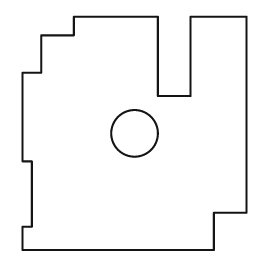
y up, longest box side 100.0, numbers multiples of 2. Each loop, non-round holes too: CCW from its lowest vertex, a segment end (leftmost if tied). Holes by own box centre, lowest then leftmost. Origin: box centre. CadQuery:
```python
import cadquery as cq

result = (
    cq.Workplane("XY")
    .moveTo(-48.0, -50.0)
    .lineTo(34.0, -50.0)
    .lineTo(34.0, -34.0)
    .lineTo(48.0, -34.0)
    .lineTo(48.0, 50.0)
    .lineTo(24.0, 50.0)
    .lineTo(24.0, 16.0)
    .lineTo(10.0, 16.0)
    .lineTo(10.0, 50.0)
    .lineTo(-26.0, 50.0)
    .lineTo(-26.0, 42.0)
    .lineTo(-40.0, 42.0)
    .lineTo(-40.0, 26.0)
    .lineTo(-48.0, 26.0)
    .lineTo(-48.0, -12.0)
    .lineTo(-44.0, -12.0)
    .lineTo(-44.0, -40.0)
    .lineTo(-48.0, -40.0)
    .close()
    .moveTo(0.0, 0.0)
    .circle(10.0)
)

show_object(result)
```